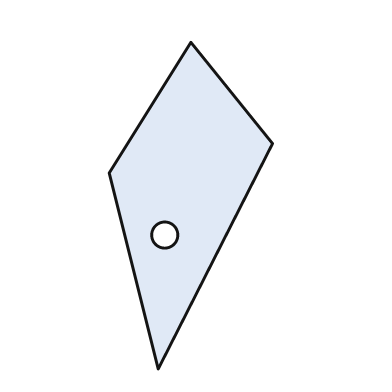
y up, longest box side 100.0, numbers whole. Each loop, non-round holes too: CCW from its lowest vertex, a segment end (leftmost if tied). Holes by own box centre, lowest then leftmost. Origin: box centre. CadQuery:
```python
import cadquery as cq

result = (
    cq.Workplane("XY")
    .moveTo(-10.0, -50.0)
    .lineTo(25.0, 19.0)
    .lineTo(0.0, 50.0)
    .lineTo(-25.0, 10.0)
    .close()
    .moveTo(-8.0, -9.0)
    .circle(4.0)
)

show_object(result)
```